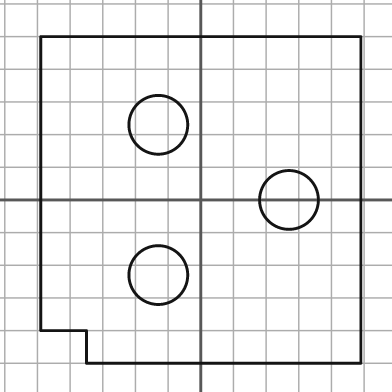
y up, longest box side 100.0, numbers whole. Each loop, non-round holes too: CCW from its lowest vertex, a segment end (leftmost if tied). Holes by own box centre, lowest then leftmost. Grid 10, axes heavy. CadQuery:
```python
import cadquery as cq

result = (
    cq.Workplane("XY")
    .moveTo(-35.0, -50.0)
    .lineTo(49.0, -50.0)
    .lineTo(49.0, 50.0)
    .lineTo(-49.0, 50.0)
    .lineTo(-49.0, -40.0)
    .lineTo(-35.0, -40.0)
    .close()
    .moveTo(-13.0, -23.0)
    .circle(9.0)
    .moveTo(27.0, 0.0)
    .circle(9.0)
    .moveTo(-13.0, 23.0)
    .circle(9.0)
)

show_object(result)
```